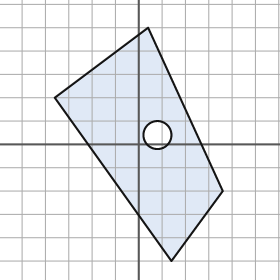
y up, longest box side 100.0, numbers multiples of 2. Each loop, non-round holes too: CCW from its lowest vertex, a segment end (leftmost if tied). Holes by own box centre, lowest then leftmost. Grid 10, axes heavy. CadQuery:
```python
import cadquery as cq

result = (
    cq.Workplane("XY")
    .moveTo(14.0, -50.0)
    .lineTo(36.0, -20.0)
    .lineTo(4.0, 50.0)
    .lineTo(-36.0, 20.0)
    .close()
    .moveTo(8.0, 4.0)
    .circle(6.0)
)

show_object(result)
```